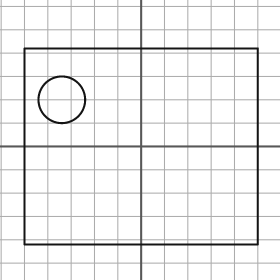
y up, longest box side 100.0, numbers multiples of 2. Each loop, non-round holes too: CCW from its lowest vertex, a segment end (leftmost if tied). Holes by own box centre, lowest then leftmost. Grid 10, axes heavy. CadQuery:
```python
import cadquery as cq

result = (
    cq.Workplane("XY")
    .moveTo(-50.0, -42.0)
    .lineTo(50.0, -42.0)
    .lineTo(50.0, 42.0)
    .lineTo(-50.0, 42.0)
    .close()
    .moveTo(-34.0, 20.0)
    .circle(10.0)
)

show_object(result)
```